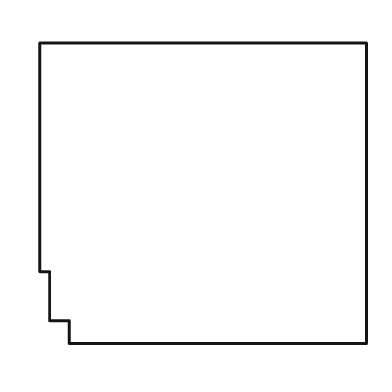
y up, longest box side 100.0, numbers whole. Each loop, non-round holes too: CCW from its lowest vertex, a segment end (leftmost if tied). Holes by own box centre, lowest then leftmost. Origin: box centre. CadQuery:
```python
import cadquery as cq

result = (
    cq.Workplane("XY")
    .moveTo(-41.0, -46.0)
    .lineTo(50.0, -46.0)
    .lineTo(50.0, 46.0)
    .lineTo(-50.0, 46.0)
    .lineTo(-50.0, -24.0)
    .lineTo(-47.0, -24.0)
    .lineTo(-47.0, -39.0)
    .lineTo(-41.0, -39.0)
    .close()
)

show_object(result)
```